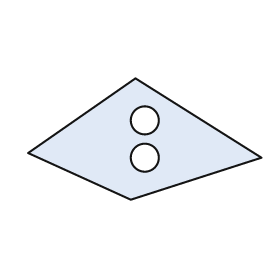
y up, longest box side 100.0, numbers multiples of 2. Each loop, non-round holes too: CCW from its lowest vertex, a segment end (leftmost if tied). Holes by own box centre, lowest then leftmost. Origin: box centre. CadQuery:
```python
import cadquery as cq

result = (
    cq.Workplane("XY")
    .moveTo(-6.0, -26.0)
    .lineTo(50.0, -8.0)
    .lineTo(-4.0, 26.0)
    .lineTo(-50.0, -6.0)
    .close()
    .moveTo(0.0, -8.0)
    .circle(6.0)
    .moveTo(0.0, 8.0)
    .circle(6.0)
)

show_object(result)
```